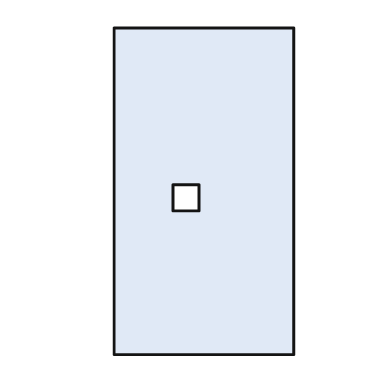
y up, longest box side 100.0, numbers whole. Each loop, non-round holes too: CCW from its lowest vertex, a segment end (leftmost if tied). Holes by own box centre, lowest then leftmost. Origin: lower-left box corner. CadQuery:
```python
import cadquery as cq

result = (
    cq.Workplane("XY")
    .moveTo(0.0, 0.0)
    .lineTo(55.0, 0.0)
    .lineTo(55.0, 100.0)
    .lineTo(0.0, 100.0)
    .close()
    .moveTo(18.0, 44.0)
    .lineTo(26.0, 44.0)
    .lineTo(26.0, 52.0)
    .lineTo(18.0, 52.0)
    .close()
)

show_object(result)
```